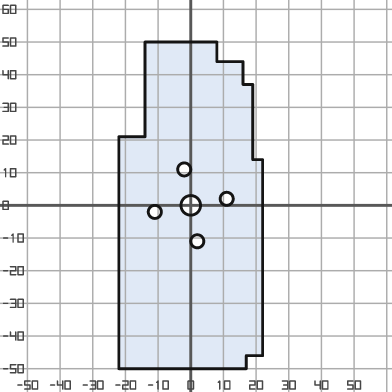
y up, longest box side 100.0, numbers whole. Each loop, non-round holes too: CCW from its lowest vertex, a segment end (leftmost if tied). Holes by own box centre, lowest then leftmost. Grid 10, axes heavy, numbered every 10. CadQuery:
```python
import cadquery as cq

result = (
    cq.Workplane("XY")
    .moveTo(-22.0, -50.0)
    .lineTo(17.0, -50.0)
    .lineTo(17.0, -46.0)
    .lineTo(22.0, -46.0)
    .lineTo(22.0, 14.0)
    .lineTo(19.0, 14.0)
    .lineTo(19.0, 37.0)
    .lineTo(16.0, 37.0)
    .lineTo(16.0, 44.0)
    .lineTo(8.0, 44.0)
    .lineTo(8.0, 50.0)
    .lineTo(-14.0, 50.0)
    .lineTo(-14.0, 21.0)
    .lineTo(-22.0, 21.0)
    .close()
    .moveTo(2.0, -11.0)
    .circle(2.0)
    .moveTo(-11.0, -2.0)
    .circle(2.0)
    .moveTo(0.0, 0.0)
    .circle(3.0)
    .moveTo(11.0, 2.0)
    .circle(2.0)
    .moveTo(-2.0, 11.0)
    .circle(2.0)
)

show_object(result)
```